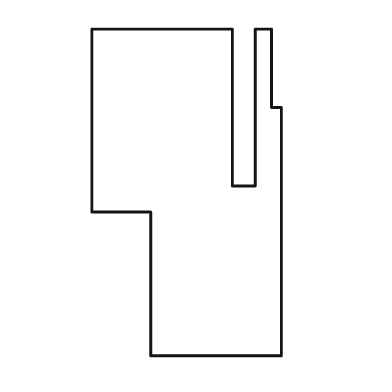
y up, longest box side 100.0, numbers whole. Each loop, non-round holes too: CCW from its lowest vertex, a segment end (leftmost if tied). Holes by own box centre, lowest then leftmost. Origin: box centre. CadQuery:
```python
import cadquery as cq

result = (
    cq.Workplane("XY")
    .moveTo(-11.0, -50.0)
    .lineTo(29.0, -50.0)
    .lineTo(29.0, 26.0)
    .lineTo(26.0, 26.0)
    .lineTo(26.0, 50.0)
    .lineTo(21.0, 50.0)
    .lineTo(21.0, 2.0)
    .lineTo(14.0, 2.0)
    .lineTo(14.0, 50.0)
    .lineTo(-29.0, 50.0)
    .lineTo(-29.0, -6.0)
    .lineTo(-11.0, -6.0)
    .close()
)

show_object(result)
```